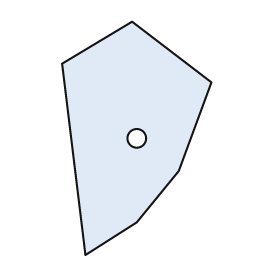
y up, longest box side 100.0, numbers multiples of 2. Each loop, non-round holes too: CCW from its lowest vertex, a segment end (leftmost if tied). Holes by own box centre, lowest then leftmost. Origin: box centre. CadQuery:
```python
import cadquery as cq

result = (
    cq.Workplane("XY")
    .moveTo(-22.0, -50.0)
    .lineTo(0.0, -36.0)
    .lineTo(18.0, -14.0)
    .lineTo(32.0, 24.0)
    .lineTo(-2.0, 50.0)
    .lineTo(-32.0, 32.0)
    .close()
    .moveTo(0.0, 0.0)
    .circle(4.0)
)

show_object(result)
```